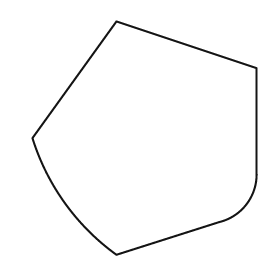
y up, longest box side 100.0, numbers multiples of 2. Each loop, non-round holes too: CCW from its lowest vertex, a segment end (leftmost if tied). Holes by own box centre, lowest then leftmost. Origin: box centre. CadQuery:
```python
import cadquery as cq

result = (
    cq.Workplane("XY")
    .moveTo(-12.0, -50.0)
    .lineTo(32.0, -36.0)
    .threePointArc((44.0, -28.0), (48.0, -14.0))
    .lineTo(48.0, 30.0)
    .lineTo(-12.0, 50.0)
    .lineTo(-48.0, 0.0)
    .threePointArc((-34.0, -28.0), (-12.0, -50.0))
    .close()
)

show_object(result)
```